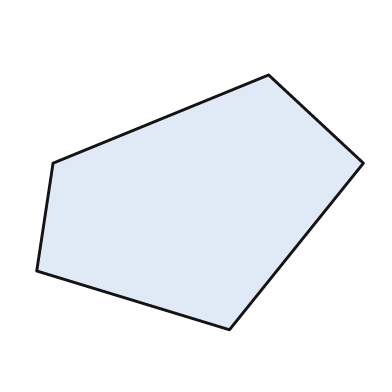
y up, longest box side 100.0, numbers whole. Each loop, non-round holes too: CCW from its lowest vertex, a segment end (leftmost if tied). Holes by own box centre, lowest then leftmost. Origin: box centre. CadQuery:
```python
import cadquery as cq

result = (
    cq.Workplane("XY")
    .moveTo(9.0, -39.0)
    .lineTo(50.0, 12.0)
    .lineTo(21.0, 39.0)
    .lineTo(-45.0, 12.0)
    .lineTo(-50.0, -21.0)
    .close()
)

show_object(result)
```